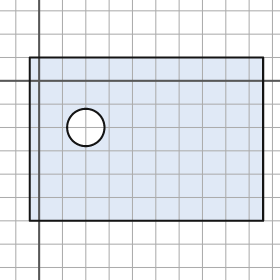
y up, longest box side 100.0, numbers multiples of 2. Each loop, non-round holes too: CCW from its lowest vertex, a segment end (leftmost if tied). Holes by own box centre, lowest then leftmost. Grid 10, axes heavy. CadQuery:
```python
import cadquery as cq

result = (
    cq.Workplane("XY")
    .moveTo(-4.0, -60.0)
    .lineTo(96.0, -60.0)
    .lineTo(96.0, 10.0)
    .lineTo(-4.0, 10.0)
    .close()
    .moveTo(20.0, -20.0)
    .circle(8.0)
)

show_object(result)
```